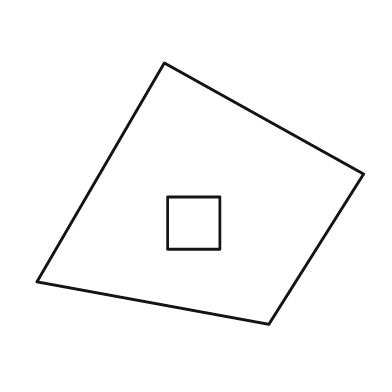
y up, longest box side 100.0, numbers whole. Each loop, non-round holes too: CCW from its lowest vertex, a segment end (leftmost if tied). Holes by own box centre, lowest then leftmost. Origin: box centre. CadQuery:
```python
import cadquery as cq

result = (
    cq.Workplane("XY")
    .moveTo(21.0, -40.0)
    .lineTo(50.0, 6.0)
    .lineTo(-11.0, 40.0)
    .lineTo(-50.0, -27.0)
    .close()
    .moveTo(-10.0, -17.0)
    .lineTo(6.0, -17.0)
    .lineTo(6.0, -1.0)
    .lineTo(-10.0, -1.0)
    .close()
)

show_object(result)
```